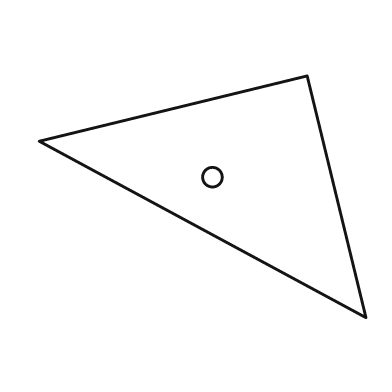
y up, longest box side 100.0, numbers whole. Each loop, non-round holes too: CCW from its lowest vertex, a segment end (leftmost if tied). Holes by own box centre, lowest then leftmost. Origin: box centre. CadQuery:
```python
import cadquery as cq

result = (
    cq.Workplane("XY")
    .moveTo(50.0, -37.0)
    .lineTo(32.0, 37.0)
    .lineTo(-50.0, 17.0)
    .close()
    .moveTo(3.0, 6.0)
    .circle(3.0)
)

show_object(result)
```